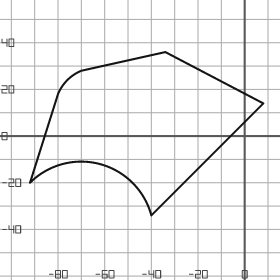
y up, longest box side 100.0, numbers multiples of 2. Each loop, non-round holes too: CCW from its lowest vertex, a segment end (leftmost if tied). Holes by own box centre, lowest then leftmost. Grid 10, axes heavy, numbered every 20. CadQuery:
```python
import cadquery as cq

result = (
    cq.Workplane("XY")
    .moveTo(-40.0, -34.0)
    .lineTo(8.0, 14.0)
    .lineTo(-34.0, 36.0)
    .lineTo(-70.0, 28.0)
    .threePointArc((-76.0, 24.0), (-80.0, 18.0))
    .lineTo(-92.0, -20.0)
    .threePointArc((-62.0, -12.0), (-40.0, -34.0))
    .close()
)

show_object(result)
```